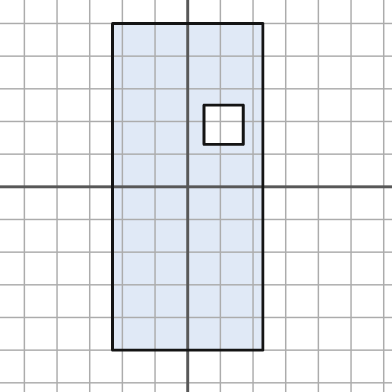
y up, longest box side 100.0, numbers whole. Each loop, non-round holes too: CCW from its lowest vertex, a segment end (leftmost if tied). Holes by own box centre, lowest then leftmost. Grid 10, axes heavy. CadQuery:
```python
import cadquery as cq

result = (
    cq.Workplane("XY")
    .moveTo(-23.0, -50.0)
    .lineTo(23.0, -50.0)
    .lineTo(23.0, 50.0)
    .lineTo(-23.0, 50.0)
    .close()
    .moveTo(5.0, 13.0)
    .lineTo(17.0, 13.0)
    .lineTo(17.0, 25.0)
    .lineTo(5.0, 25.0)
    .close()
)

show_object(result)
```